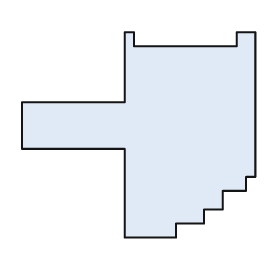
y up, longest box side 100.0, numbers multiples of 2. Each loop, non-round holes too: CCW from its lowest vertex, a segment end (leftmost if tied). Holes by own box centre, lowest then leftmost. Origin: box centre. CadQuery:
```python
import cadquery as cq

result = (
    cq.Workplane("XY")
    .moveTo(-6.0, -44.0)
    .lineTo(16.0, -44.0)
    .lineTo(16.0, -38.0)
    .lineTo(28.0, -38.0)
    .lineTo(28.0, -32.0)
    .lineTo(36.0, -32.0)
    .lineTo(36.0, -24.0)
    .lineTo(46.0, -24.0)
    .lineTo(46.0, -18.0)
    .lineTo(50.0, -18.0)
    .lineTo(50.0, 44.0)
    .lineTo(42.0, 44.0)
    .lineTo(42.0, 38.0)
    .lineTo(-2.0, 38.0)
    .lineTo(-2.0, 44.0)
    .lineTo(-6.0, 44.0)
    .lineTo(-6.0, 14.0)
    .lineTo(-50.0, 14.0)
    .lineTo(-50.0, -6.0)
    .lineTo(-6.0, -6.0)
    .close()
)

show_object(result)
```